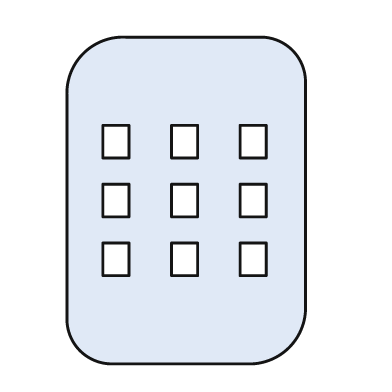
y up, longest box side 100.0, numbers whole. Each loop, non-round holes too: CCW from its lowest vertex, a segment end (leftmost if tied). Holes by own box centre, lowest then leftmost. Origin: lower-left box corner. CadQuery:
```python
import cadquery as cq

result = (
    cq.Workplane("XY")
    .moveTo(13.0, 0.0)
    .lineTo(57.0, 0.0)
    .threePointArc((68.0, 5.0), (73.0, 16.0))
    .lineTo(73.0, 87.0)
    .threePointArc((69.0, 96.0), (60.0, 100.0))
    .lineTo(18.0, 100.0)
    .threePointArc((5.0, 95.0), (0.0, 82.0))
    .lineTo(0.0, 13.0)
    .threePointArc((4.0, 4.0), (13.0, 0.0))
    .close()
    .moveTo(11.0, 27.0)
    .lineTo(19.0, 27.0)
    .lineTo(19.0, 37.0)
    .lineTo(11.0, 37.0)
    .close()
    .moveTo(32.0, 27.0)
    .lineTo(40.0, 27.0)
    .lineTo(40.0, 37.0)
    .lineTo(32.0, 37.0)
    .close()
    .moveTo(53.0, 27.0)
    .lineTo(61.0, 27.0)
    .lineTo(61.0, 37.0)
    .lineTo(53.0, 37.0)
    .close()
    .moveTo(11.0, 45.0)
    .lineTo(19.0, 45.0)
    .lineTo(19.0, 55.0)
    .lineTo(11.0, 55.0)
    .close()
    .moveTo(32.0, 45.0)
    .lineTo(40.0, 45.0)
    .lineTo(40.0, 55.0)
    .lineTo(32.0, 55.0)
    .close()
    .moveTo(53.0, 45.0)
    .lineTo(61.0, 45.0)
    .lineTo(61.0, 55.0)
    .lineTo(53.0, 55.0)
    .close()
    .moveTo(11.0, 63.0)
    .lineTo(19.0, 63.0)
    .lineTo(19.0, 73.0)
    .lineTo(11.0, 73.0)
    .close()
    .moveTo(32.0, 63.0)
    .lineTo(40.0, 63.0)
    .lineTo(40.0, 73.0)
    .lineTo(32.0, 73.0)
    .close()
    .moveTo(53.0, 63.0)
    .lineTo(61.0, 63.0)
    .lineTo(61.0, 73.0)
    .lineTo(53.0, 73.0)
    .close()
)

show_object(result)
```